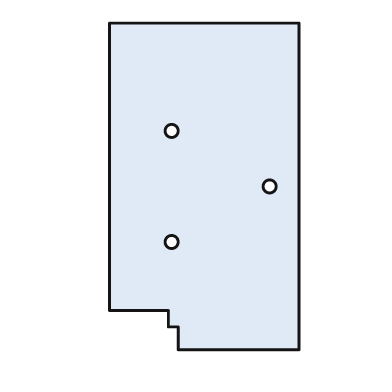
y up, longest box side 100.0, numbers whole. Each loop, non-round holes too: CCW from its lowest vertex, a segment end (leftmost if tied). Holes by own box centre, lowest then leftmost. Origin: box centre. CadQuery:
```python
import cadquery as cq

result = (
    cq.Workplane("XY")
    .moveTo(-8.0, -50.0)
    .lineTo(29.0, -50.0)
    .lineTo(29.0, 50.0)
    .lineTo(-29.0, 50.0)
    .lineTo(-29.0, -38.0)
    .lineTo(-11.0, -38.0)
    .lineTo(-11.0, -43.0)
    .lineTo(-8.0, -43.0)
    .close()
    .moveTo(-10.0, -17.0)
    .circle(2.0)
    .moveTo(20.0, 0.0)
    .circle(2.0)
    .moveTo(-10.0, 17.0)
    .circle(2.0)
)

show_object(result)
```